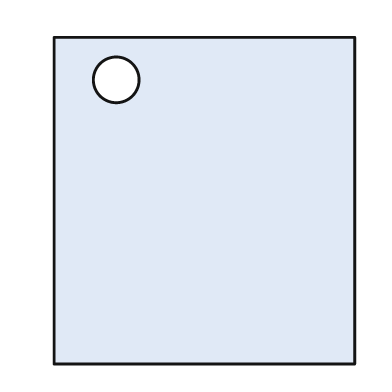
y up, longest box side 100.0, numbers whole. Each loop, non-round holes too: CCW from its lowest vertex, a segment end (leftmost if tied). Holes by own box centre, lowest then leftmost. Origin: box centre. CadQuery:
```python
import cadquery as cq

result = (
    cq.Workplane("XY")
    .moveTo(-46.0, -50.0)
    .lineTo(46.0, -50.0)
    .lineTo(46.0, 50.0)
    .lineTo(-46.0, 50.0)
    .close()
    .moveTo(-27.0, 37.0)
    .circle(7.0)
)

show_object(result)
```